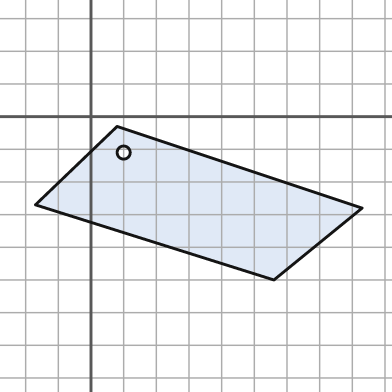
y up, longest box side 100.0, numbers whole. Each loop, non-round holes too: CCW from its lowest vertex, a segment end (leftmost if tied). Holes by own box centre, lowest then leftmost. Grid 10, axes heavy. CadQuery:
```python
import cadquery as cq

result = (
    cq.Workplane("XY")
    .moveTo(56.0, -50.0)
    .lineTo(83.0, -28.0)
    .lineTo(8.0, -3.0)
    .lineTo(-17.0, -27.0)
    .close()
    .moveTo(10.0, -11.0)
    .circle(2.0)
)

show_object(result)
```